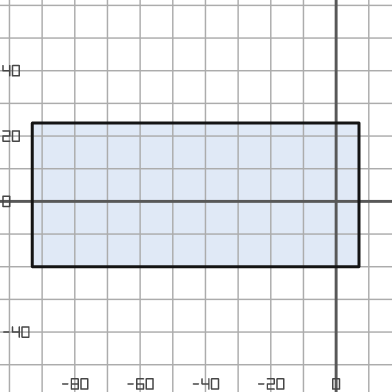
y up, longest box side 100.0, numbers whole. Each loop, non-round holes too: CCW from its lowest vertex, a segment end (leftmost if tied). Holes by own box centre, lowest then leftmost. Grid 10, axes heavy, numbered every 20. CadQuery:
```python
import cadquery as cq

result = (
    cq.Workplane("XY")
    .moveTo(-93.0, -20.0)
    .lineTo(7.0, -20.0)
    .lineTo(7.0, 24.0)
    .lineTo(-93.0, 24.0)
    .close()
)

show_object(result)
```